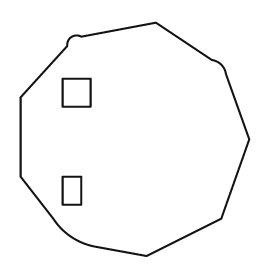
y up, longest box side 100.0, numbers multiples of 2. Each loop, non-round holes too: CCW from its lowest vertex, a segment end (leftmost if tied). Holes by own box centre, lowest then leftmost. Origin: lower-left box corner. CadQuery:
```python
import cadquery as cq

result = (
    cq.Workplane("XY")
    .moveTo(54.0, 0.0)
    .lineTo(86.0, 16.0)
    .lineTo(98.0, 50.0)
    .lineTo(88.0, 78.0)
    .threePointArc((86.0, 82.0), (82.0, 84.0))
    .lineTo(58.0, 100.0)
    .lineTo(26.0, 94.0)
    .threePointArc((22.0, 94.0), (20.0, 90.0))
    .lineTo(0.0, 68.0)
    .lineTo(0.0, 34.0)
    .lineTo(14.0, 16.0)
    .threePointArc((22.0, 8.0), (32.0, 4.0))
    .close()
    .moveTo(18.0, 22.0)
    .lineTo(26.0, 22.0)
    .lineTo(26.0, 34.0)
    .lineTo(18.0, 34.0)
    .close()
    .moveTo(18.0, 64.0)
    .lineTo(30.0, 64.0)
    .lineTo(30.0, 76.0)
    .lineTo(18.0, 76.0)
    .close()
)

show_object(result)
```